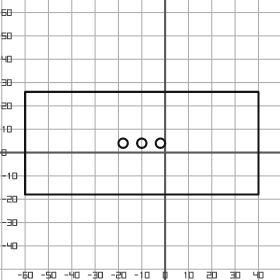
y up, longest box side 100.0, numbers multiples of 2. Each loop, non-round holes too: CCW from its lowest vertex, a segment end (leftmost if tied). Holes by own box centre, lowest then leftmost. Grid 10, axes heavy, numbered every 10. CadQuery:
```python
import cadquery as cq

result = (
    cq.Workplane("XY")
    .moveTo(-60.0, -18.0)
    .lineTo(40.0, -18.0)
    .lineTo(40.0, 26.0)
    .lineTo(-60.0, 26.0)
    .close()
    .moveTo(-18.0, 4.0)
    .circle(2.0)
    .moveTo(-10.0, 4.0)
    .circle(2.0)
    .moveTo(-2.0, 4.0)
    .circle(2.0)
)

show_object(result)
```